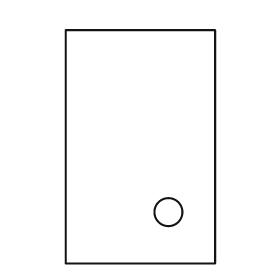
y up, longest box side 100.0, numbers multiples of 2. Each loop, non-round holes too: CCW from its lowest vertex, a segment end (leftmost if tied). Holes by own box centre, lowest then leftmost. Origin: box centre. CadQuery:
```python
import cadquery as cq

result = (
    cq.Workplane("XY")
    .moveTo(-32.0, -50.0)
    .lineTo(32.0, -50.0)
    .lineTo(32.0, 50.0)
    .lineTo(-32.0, 50.0)
    .close()
    .moveTo(12.0, -28.0)
    .circle(6.0)
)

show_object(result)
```